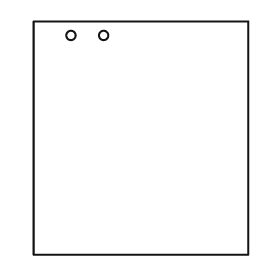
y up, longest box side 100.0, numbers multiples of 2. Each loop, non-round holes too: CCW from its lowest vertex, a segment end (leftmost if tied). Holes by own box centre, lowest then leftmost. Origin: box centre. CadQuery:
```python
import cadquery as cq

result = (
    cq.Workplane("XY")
    .moveTo(-46.0, -50.0)
    .lineTo(46.0, -50.0)
    .lineTo(46.0, 50.0)
    .lineTo(-46.0, 50.0)
    .close()
    .moveTo(-30.0, 44.0)
    .circle(2.0)
    .moveTo(-16.0, 44.0)
    .circle(2.0)
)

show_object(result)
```